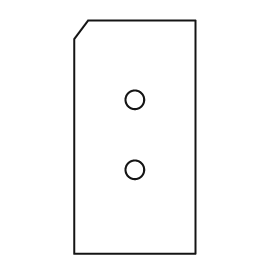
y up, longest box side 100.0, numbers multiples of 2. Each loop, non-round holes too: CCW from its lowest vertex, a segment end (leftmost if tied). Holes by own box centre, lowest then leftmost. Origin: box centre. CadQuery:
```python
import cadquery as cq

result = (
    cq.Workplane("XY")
    .moveTo(-26.0, -50.0)
    .lineTo(26.0, -50.0)
    .lineTo(26.0, 50.0)
    .lineTo(-20.0, 50.0)
    .lineTo(-26.0, 42.0)
    .close()
    .moveTo(0.0, -14.0)
    .circle(4.0)
    .moveTo(0.0, 16.0)
    .circle(4.0)
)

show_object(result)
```